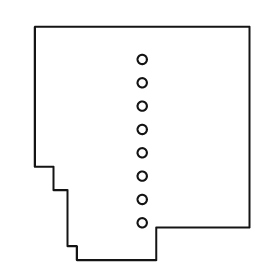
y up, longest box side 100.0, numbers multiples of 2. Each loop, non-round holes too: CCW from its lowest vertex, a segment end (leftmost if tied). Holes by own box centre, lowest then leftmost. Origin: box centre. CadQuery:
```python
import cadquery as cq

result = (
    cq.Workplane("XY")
    .moveTo(-28.0, -50.0)
    .lineTo(6.0, -50.0)
    .lineTo(6.0, -36.0)
    .lineTo(46.0, -36.0)
    .lineTo(46.0, 50.0)
    .lineTo(-46.0, 50.0)
    .lineTo(-46.0, -10.0)
    .lineTo(-38.0, -10.0)
    .lineTo(-38.0, -20.0)
    .lineTo(-32.0, -20.0)
    .lineTo(-32.0, -44.0)
    .lineTo(-28.0, -44.0)
    .close()
    .moveTo(0.0, -34.0)
    .circle(2.0)
    .moveTo(0.0, -24.0)
    .circle(2.0)
    .moveTo(0.0, -14.0)
    .circle(2.0)
    .moveTo(0.0, -4.0)
    .circle(2.0)
    .moveTo(0.0, 6.0)
    .circle(2.0)
    .moveTo(0.0, 16.0)
    .circle(2.0)
    .moveTo(0.0, 26.0)
    .circle(2.0)
    .moveTo(0.0, 36.0)
    .circle(2.0)
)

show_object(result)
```